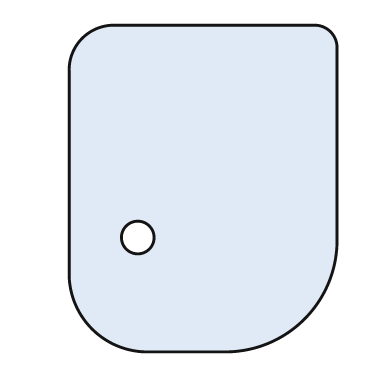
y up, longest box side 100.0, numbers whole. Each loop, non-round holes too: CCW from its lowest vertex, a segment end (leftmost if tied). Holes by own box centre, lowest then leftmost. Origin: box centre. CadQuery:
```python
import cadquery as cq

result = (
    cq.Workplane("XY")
    .moveTo(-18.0, -50.0)
    .lineTo(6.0, -50.0)
    .threePointArc((31.0, -40.0), (41.0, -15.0))
    .lineTo(41.0, 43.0)
    .threePointArc((39.0, 48.0), (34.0, 50.0))
    .lineTo(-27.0, 50.0)
    .threePointArc((-37.0, 46.0), (-41.0, 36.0))
    .lineTo(-41.0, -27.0)
    .threePointArc((-34.0, -43.0), (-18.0, -50.0))
    .close()
    .moveTo(-20.0, -15.0)
    .circle(5.0)
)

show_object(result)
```